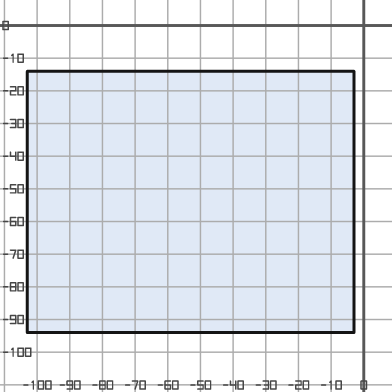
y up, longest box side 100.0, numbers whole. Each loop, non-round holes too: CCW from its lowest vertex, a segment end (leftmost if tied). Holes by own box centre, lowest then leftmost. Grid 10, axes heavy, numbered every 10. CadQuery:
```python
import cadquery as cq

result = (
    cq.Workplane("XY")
    .moveTo(-103.0, -94.0)
    .lineTo(-3.0, -94.0)
    .lineTo(-3.0, -14.0)
    .lineTo(-103.0, -14.0)
    .close()
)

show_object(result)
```